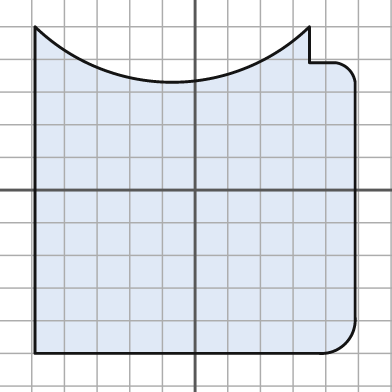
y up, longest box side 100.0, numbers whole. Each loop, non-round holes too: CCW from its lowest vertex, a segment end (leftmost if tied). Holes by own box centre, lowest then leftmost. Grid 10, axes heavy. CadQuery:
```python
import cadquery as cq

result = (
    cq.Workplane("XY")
    .moveTo(-49.0, -50.0)
    .lineTo(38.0, -50.0)
    .threePointArc((46.0, -47.0), (49.0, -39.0))
    .lineTo(49.0, 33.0)
    .threePointArc((47.0, 37.0), (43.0, 39.0))
    .lineTo(35.0, 39.0)
    .lineTo(35.0, 50.0)
    .threePointArc((-7.0, 33.0), (-49.0, 50.0))
    .close()
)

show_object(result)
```